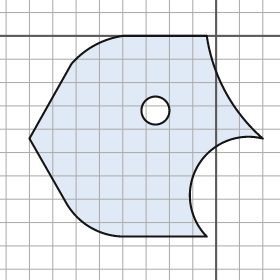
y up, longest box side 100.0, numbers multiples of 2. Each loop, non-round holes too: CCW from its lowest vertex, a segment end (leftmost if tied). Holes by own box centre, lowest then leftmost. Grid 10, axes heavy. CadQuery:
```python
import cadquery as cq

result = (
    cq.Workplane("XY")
    .moveTo(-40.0, -86.0)
    .lineTo(-4.0, -86.0)
    .threePointArc((-8.0, -56.0), (20.0, -44.0))
    .threePointArc((4.0, -24.0), (-4.0, 0.0))
    .lineTo(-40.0, 0.0)
    .threePointArc((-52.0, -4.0), (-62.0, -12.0))
    .lineTo(-80.0, -44.0)
    .lineTo(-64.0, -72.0)
    .threePointArc((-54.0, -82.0), (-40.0, -86.0))
    .close()
    .moveTo(-26.0, -32.0)
    .circle(6.0)
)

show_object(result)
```